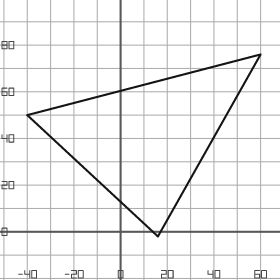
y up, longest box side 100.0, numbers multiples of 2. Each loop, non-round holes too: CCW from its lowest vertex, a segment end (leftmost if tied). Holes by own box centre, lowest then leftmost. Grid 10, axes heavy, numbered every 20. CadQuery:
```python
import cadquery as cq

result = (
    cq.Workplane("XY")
    .moveTo(16.0, -2.0)
    .lineTo(60.0, 76.0)
    .lineTo(-40.0, 50.0)
    .close()
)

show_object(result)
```